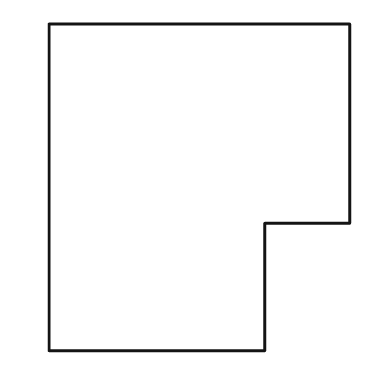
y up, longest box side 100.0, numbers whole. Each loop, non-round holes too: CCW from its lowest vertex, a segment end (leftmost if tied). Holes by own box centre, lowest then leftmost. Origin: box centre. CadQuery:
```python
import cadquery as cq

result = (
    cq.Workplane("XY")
    .moveTo(-46.0, -50.0)
    .lineTo(20.0, -50.0)
    .lineTo(20.0, -11.0)
    .lineTo(46.0, -11.0)
    .lineTo(46.0, 50.0)
    .lineTo(-46.0, 50.0)
    .close()
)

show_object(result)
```